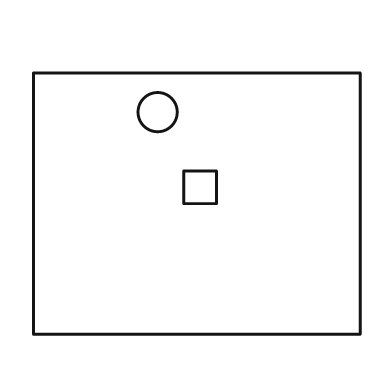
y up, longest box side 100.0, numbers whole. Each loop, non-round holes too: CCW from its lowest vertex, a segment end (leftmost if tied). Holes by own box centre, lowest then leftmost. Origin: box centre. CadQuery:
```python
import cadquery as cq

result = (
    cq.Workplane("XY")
    .moveTo(-50.0, -40.0)
    .lineTo(50.0, -40.0)
    .lineTo(50.0, 40.0)
    .lineTo(-50.0, 40.0)
    .close()
    .moveTo(-4.0, 0.0)
    .lineTo(6.0, 0.0)
    .lineTo(6.0, 10.0)
    .lineTo(-4.0, 10.0)
    .close()
    .moveTo(-12.0, 28.0)
    .circle(6.0)
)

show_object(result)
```